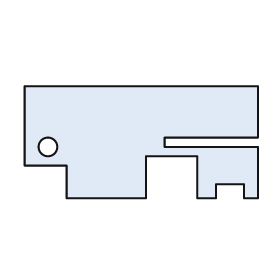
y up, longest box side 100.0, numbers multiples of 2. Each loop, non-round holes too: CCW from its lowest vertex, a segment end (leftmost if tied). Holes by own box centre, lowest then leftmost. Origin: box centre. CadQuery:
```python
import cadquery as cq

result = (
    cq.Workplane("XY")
    .moveTo(-32.0, -24.0)
    .lineTo(2.0, -24.0)
    .lineTo(2.0, -6.0)
    .lineTo(24.0, -6.0)
    .lineTo(24.0, -24.0)
    .lineTo(32.0, -24.0)
    .lineTo(32.0, -18.0)
    .lineTo(44.0, -18.0)
    .lineTo(44.0, -24.0)
    .lineTo(50.0, -24.0)
    .lineTo(50.0, -2.0)
    .lineTo(10.0, -2.0)
    .lineTo(10.0, 2.0)
    .lineTo(50.0, 2.0)
    .lineTo(50.0, 24.0)
    .lineTo(-50.0, 24.0)
    .lineTo(-50.0, -10.0)
    .lineTo(-32.0, -10.0)
    .close()
    .moveTo(-40.0, -2.0)
    .circle(4.0)
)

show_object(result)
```